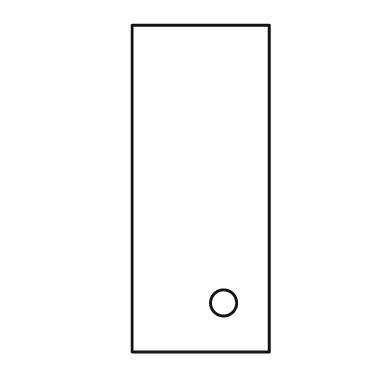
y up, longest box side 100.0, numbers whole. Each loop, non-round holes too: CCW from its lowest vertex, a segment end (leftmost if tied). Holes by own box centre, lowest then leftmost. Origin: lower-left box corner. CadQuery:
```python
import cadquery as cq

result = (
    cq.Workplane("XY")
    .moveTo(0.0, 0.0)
    .lineTo(42.0, 0.0)
    .lineTo(42.0, 100.0)
    .lineTo(0.0, 100.0)
    .close()
    .moveTo(28.0, 15.0)
    .circle(4.0)
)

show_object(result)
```